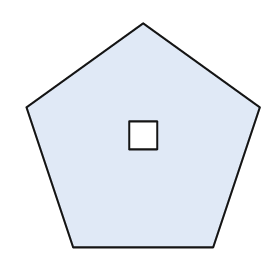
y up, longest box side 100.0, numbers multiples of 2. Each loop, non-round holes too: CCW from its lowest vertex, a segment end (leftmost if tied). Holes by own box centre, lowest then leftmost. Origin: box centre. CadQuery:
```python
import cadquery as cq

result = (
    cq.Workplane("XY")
    .moveTo(-30.0, -48.0)
    .lineTo(30.0, -48.0)
    .lineTo(50.0, 12.0)
    .lineTo(0.0, 48.0)
    .lineTo(-50.0, 12.0)
    .close()
    .moveTo(-6.0, -6.0)
    .lineTo(6.0, -6.0)
    .lineTo(6.0, 6.0)
    .lineTo(-6.0, 6.0)
    .close()
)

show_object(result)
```